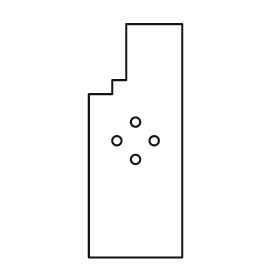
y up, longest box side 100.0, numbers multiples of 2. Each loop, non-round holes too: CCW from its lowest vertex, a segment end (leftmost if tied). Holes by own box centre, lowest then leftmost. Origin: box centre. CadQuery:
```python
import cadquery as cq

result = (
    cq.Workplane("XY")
    .moveTo(-20.0, -50.0)
    .lineTo(20.0, -50.0)
    .lineTo(20.0, 50.0)
    .lineTo(-4.0, 50.0)
    .lineTo(-4.0, 26.0)
    .lineTo(-10.0, 26.0)
    .lineTo(-10.0, 20.0)
    .lineTo(-20.0, 20.0)
    .close()
    .moveTo(0.0, -8.0)
    .circle(2.0)
    .moveTo(-8.0, 0.0)
    .circle(2.0)
    .moveTo(8.0, 0.0)
    .circle(2.0)
    .moveTo(0.0, 8.0)
    .circle(2.0)
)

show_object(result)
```